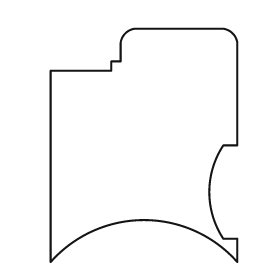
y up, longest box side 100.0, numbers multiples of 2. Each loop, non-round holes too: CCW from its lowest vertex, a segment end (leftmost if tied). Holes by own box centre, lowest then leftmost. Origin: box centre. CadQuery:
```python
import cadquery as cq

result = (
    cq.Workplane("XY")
    .moveTo(-40.0, -50.0)
    .threePointArc((0.0, -32.0), (40.0, -50.0))
    .lineTo(40.0, -40.0)
    .lineTo(34.0, -40.0)
    .threePointArc((28.0, -20.0), (34.0, 0.0))
    .lineTo(40.0, 0.0)
    .lineTo(40.0, 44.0)
    .threePointArc((38.0, 48.0), (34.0, 50.0))
    .lineTo(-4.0, 50.0)
    .threePointArc((-8.0, 48.0), (-10.0, 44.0))
    .lineTo(-10.0, 36.0)
    .lineTo(-14.0, 36.0)
    .lineTo(-14.0, 32.0)
    .lineTo(-40.0, 32.0)
    .close()
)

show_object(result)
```